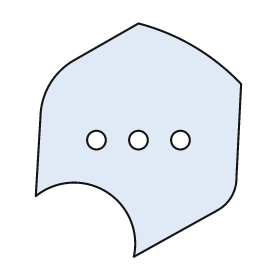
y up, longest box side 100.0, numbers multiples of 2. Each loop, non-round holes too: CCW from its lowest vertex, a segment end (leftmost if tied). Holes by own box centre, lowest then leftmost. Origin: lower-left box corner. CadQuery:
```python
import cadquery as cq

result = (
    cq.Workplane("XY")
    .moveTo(42.0, 0.0)
    .lineTo(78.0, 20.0)
    .threePointArc((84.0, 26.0), (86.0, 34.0))
    .lineTo(88.0, 74.0)
    .threePointArc((68.0, 90.0), (44.0, 100.0))
    .lineTo(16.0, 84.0)
    .threePointArc((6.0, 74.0), (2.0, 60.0))
    .lineTo(0.0, 26.0)
    .threePointArc((30.0, 28.0), (42.0, 0.0))
    .close()
    .moveTo(26.0, 50.0)
    .circle(4.0)
    .moveTo(44.0, 50.0)
    .circle(4.0)
    .moveTo(62.0, 50.0)
    .circle(4.0)
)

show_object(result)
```